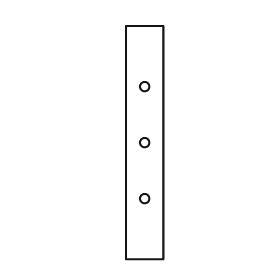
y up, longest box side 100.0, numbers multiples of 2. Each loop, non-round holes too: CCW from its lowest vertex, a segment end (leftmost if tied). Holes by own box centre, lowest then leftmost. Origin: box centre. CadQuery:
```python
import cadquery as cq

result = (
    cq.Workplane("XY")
    .moveTo(-8.0, -50.0)
    .lineTo(8.0, -50.0)
    .lineTo(8.0, 50.0)
    .lineTo(-8.0, 50.0)
    .close()
    .moveTo(0.0, -24.0)
    .circle(2.0)
    .moveTo(0.0, 0.0)
    .circle(2.0)
    .moveTo(0.0, 24.0)
    .circle(2.0)
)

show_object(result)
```